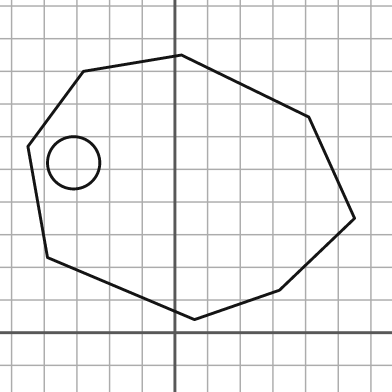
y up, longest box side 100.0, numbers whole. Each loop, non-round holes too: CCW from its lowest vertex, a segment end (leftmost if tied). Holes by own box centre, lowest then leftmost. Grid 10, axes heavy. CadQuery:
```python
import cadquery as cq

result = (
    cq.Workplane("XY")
    .moveTo(6.0, 4.0)
    .lineTo(32.0, 13.0)
    .lineTo(55.0, 35.0)
    .lineTo(41.0, 66.0)
    .lineTo(2.0, 85.0)
    .lineTo(-28.0, 80.0)
    .lineTo(-45.0, 57.0)
    .lineTo(-39.0, 23.0)
    .close()
    .moveTo(-31.0, 52.0)
    .circle(8.0)
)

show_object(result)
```